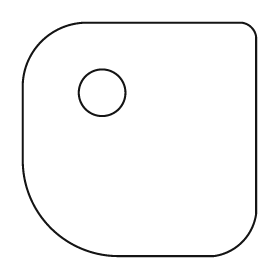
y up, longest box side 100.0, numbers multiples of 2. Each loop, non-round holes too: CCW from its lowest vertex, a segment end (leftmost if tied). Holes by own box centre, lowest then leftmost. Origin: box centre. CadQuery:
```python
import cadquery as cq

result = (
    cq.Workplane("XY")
    .moveTo(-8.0, -50.0)
    .lineTo(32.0, -50.0)
    .threePointArc((44.0, -44.0), (50.0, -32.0))
    .lineTo(50.0, 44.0)
    .threePointArc((48.0, 48.0), (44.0, 50.0))
    .lineTo(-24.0, 50.0)
    .threePointArc((-42.0, 42.0), (-50.0, 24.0))
    .lineTo(-50.0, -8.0)
    .threePointArc((-38.0, -38.0), (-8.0, -50.0))
    .close()
    .moveTo(-16.0, 20.0)
    .circle(10.0)
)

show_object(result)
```